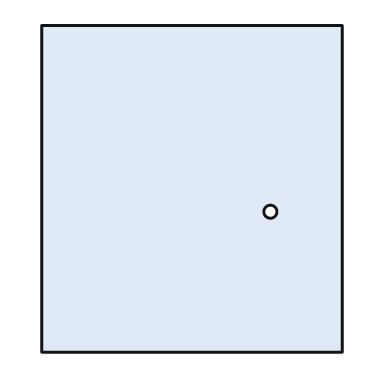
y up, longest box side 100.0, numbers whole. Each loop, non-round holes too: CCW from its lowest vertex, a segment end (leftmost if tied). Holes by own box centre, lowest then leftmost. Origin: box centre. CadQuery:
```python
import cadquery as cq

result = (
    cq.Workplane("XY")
    .moveTo(-46.0, -50.0)
    .lineTo(46.0, -50.0)
    .lineTo(46.0, 50.0)
    .lineTo(-46.0, 50.0)
    .close()
    .moveTo(24.0, -7.0)
    .circle(2.0)
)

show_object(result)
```